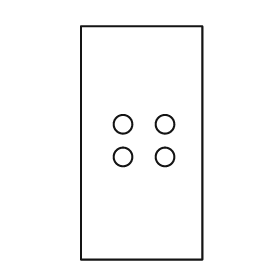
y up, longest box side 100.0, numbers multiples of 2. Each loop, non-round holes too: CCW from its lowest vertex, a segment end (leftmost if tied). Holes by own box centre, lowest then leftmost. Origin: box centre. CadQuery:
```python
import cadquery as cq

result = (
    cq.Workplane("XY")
    .moveTo(-26.0, -50.0)
    .lineTo(26.0, -50.0)
    .lineTo(26.0, 50.0)
    .lineTo(-26.0, 50.0)
    .close()
    .moveTo(-8.0, -6.0)
    .circle(4.0)
    .moveTo(10.0, -6.0)
    .circle(4.0)
    .moveTo(-8.0, 8.0)
    .circle(4.0)
    .moveTo(10.0, 8.0)
    .circle(4.0)
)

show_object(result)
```